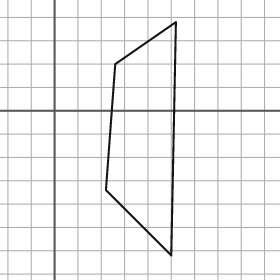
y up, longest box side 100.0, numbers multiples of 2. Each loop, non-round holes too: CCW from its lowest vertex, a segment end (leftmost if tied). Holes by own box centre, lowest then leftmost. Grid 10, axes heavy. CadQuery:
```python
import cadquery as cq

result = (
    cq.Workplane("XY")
    .moveTo(50.0, -62.0)
    .lineTo(52.0, 38.0)
    .lineTo(26.0, 20.0)
    .lineTo(22.0, -34.0)
    .close()
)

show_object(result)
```